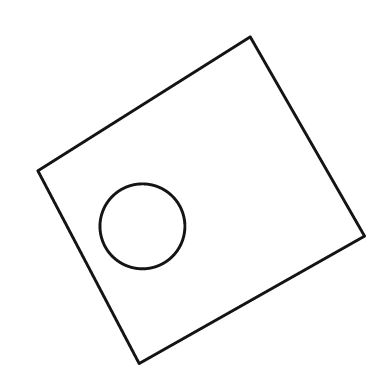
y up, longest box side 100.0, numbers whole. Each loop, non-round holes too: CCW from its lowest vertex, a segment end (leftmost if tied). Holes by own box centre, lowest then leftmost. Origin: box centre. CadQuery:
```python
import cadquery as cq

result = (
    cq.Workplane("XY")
    .moveTo(-19.0, -50.0)
    .lineTo(50.0, -11.0)
    .lineTo(15.0, 50.0)
    .lineTo(-50.0, 9.0)
    .close()
    .moveTo(-18.0, -8.0)
    .circle(13.0)
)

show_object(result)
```